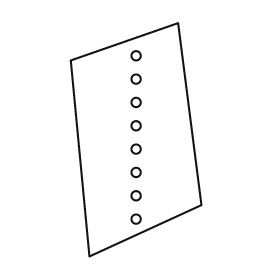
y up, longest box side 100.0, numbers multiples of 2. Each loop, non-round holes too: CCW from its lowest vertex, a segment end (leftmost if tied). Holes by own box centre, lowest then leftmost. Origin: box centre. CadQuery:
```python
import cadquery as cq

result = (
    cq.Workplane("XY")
    .moveTo(-20.0, -50.0)
    .lineTo(28.0, -28.0)
    .lineTo(18.0, 50.0)
    .lineTo(-28.0, 34.0)
    .close()
    .moveTo(0.0, -34.0)
    .circle(2.0)
    .moveTo(0.0, -24.0)
    .circle(2.0)
    .moveTo(0.0, -14.0)
    .circle(2.0)
    .moveTo(0.0, -4.0)
    .circle(2.0)
    .moveTo(0.0, 6.0)
    .circle(2.0)
    .moveTo(0.0, 16.0)
    .circle(2.0)
    .moveTo(0.0, 26.0)
    .circle(2.0)
    .moveTo(0.0, 36.0)
    .circle(2.0)
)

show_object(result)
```